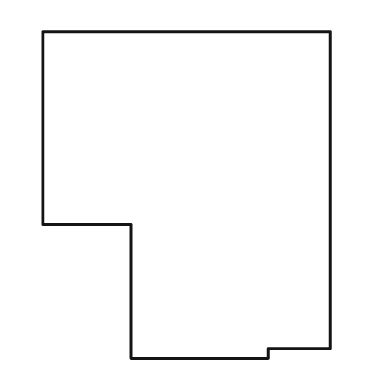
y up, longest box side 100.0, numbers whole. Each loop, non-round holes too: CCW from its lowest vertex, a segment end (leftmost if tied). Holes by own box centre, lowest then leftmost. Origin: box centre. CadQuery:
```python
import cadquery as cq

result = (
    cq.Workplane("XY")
    .moveTo(-17.0, -50.0)
    .lineTo(25.0, -50.0)
    .lineTo(25.0, -47.0)
    .lineTo(44.0, -47.0)
    .lineTo(44.0, 50.0)
    .lineTo(-44.0, 50.0)
    .lineTo(-44.0, -9.0)
    .lineTo(-17.0, -9.0)
    .close()
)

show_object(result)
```